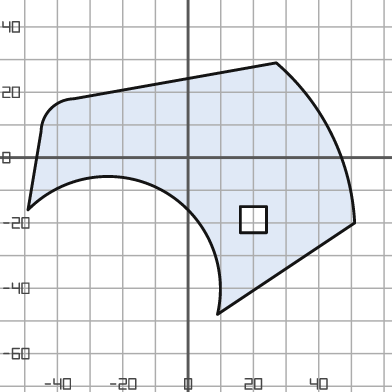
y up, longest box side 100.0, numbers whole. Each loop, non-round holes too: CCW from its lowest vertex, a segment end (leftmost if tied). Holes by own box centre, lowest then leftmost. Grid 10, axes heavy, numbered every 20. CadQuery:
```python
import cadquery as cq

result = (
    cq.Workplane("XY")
    .moveTo(9.0, -48.0)
    .lineTo(51.0, -20.0)
    .threePointArc((44.0, 7.0), (27.0, 29.0))
    .lineTo(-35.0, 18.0)
    .threePointArc((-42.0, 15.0), (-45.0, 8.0))
    .lineTo(-49.0, -16.0)
    .threePointArc((-8.0, -10.0), (9.0, -48.0))
    .close()
    .moveTo(16.0, -23.0)
    .lineTo(24.0, -23.0)
    .lineTo(24.0, -15.0)
    .lineTo(16.0, -15.0)
    .close()
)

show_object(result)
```